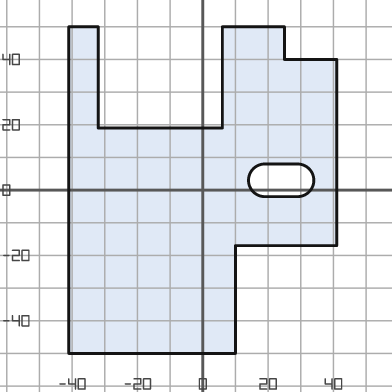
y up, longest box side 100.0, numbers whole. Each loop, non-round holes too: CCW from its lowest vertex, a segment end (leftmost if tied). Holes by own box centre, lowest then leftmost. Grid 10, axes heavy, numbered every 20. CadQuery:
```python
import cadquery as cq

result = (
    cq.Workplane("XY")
    .moveTo(-41.0, -50.0)
    .lineTo(10.0, -50.0)
    .lineTo(10.0, -17.0)
    .lineTo(41.0, -17.0)
    .lineTo(41.0, 40.0)
    .lineTo(25.0, 40.0)
    .lineTo(25.0, 50.0)
    .lineTo(6.0, 50.0)
    .lineTo(6.0, 19.0)
    .lineTo(-32.0, 19.0)
    .lineTo(-32.0, 50.0)
    .lineTo(-41.0, 50.0)
    .close()
    .moveTo(19.0, -2.0)
    .lineTo(29.0, -2.0)
    .threePointArc((34.0, 3.0), (29.0, 8.0))
    .lineTo(19.0, 8.0)
    .threePointArc((14.0, 3.0), (19.0, -2.0))
    .close()
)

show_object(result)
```